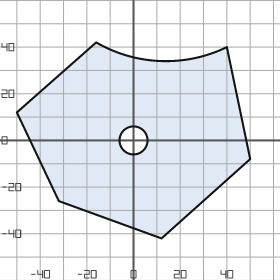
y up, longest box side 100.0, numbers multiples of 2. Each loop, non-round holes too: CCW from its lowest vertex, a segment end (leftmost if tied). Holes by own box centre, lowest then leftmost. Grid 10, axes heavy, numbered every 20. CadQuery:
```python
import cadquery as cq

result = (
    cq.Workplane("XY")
    .moveTo(12.0, -42.0)
    .lineTo(50.0, -8.0)
    .lineTo(40.0, 40.0)
    .threePointArc((12.0, 34.0), (-16.0, 42.0))
    .lineTo(-50.0, 12.0)
    .lineTo(-32.0, -26.0)
    .close()
    .moveTo(0.0, 0.0)
    .circle(6.0)
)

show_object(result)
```